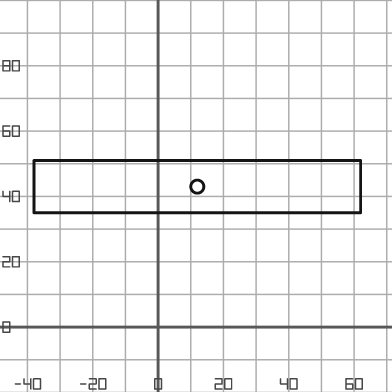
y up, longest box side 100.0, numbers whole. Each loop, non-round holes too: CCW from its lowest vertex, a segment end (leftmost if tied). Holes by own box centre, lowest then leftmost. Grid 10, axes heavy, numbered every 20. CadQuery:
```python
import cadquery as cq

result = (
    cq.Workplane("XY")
    .moveTo(-38.0, 35.0)
    .lineTo(62.0, 35.0)
    .lineTo(62.0, 51.0)
    .lineTo(-38.0, 51.0)
    .close()
    .moveTo(12.0, 43.0)
    .circle(2.0)
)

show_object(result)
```